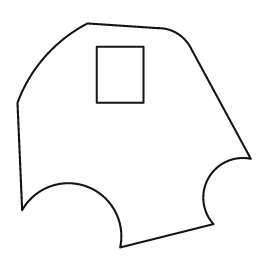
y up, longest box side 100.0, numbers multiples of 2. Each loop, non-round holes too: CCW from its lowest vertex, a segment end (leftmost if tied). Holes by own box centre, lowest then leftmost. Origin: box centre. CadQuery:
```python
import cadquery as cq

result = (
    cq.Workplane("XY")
    .moveTo(-6.0, -48.0)
    .lineTo(34.0, -38.0)
    .threePointArc((32.0, -18.0), (50.0, -10.0))
    .lineTo(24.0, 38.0)
    .threePointArc((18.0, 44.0), (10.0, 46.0))
    .lineTo(-20.0, 48.0)
    .threePointArc((-38.0, 34.0), (-50.0, 14.0))
    .lineTo(-48.0, -32.0)
    .threePointArc((-20.0, -22.0), (-6.0, -48.0))
    .close()
    .moveTo(-16.0, 14.0)
    .lineTo(4.0, 14.0)
    .lineTo(4.0, 38.0)
    .lineTo(-16.0, 38.0)
    .close()
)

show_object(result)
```